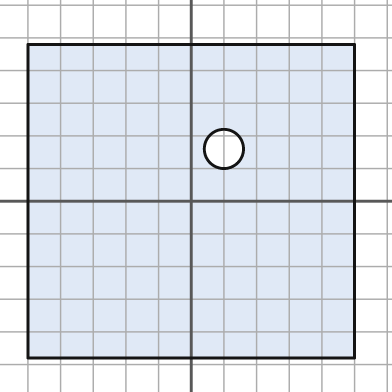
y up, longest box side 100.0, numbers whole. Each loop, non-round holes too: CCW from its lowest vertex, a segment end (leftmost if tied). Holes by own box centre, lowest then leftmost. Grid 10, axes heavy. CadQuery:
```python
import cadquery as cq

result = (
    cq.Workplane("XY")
    .moveTo(-50.0, -48.0)
    .lineTo(50.0, -48.0)
    .lineTo(50.0, 48.0)
    .lineTo(-50.0, 48.0)
    .close()
    .moveTo(10.0, 16.0)
    .circle(6.0)
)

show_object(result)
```